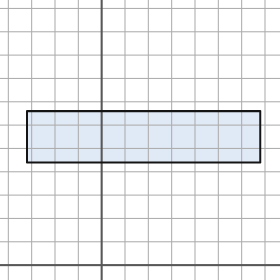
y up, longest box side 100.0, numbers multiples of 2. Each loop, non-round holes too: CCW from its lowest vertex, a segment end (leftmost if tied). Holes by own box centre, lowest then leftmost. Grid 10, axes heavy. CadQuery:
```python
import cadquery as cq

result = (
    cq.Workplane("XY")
    .moveTo(-32.0, 44.0)
    .lineTo(68.0, 44.0)
    .lineTo(68.0, 66.0)
    .lineTo(-32.0, 66.0)
    .close()
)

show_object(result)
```